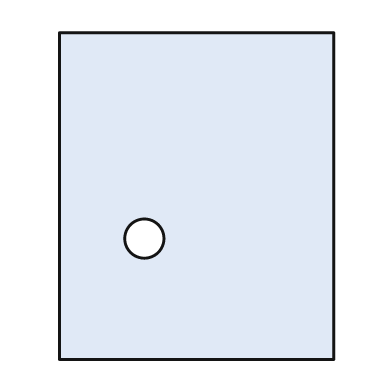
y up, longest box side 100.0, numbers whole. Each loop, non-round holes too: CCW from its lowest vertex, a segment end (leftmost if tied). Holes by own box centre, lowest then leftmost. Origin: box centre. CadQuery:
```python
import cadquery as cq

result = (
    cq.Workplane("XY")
    .moveTo(-42.0, -50.0)
    .lineTo(42.0, -50.0)
    .lineTo(42.0, 50.0)
    .lineTo(-42.0, 50.0)
    .close()
    .moveTo(-16.0, -13.0)
    .circle(6.0)
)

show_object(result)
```